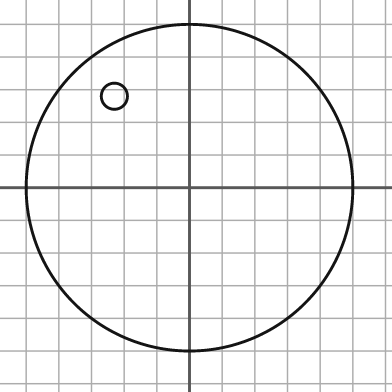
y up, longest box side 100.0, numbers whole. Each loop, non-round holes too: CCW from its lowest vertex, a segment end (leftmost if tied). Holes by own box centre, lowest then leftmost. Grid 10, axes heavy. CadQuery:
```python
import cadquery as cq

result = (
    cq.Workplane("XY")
    .moveTo(0.0, 0.0)
    .circle(50.0)
    .moveTo(-23.0, 28.0)
    .circle(4.0)
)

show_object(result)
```